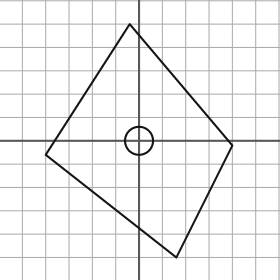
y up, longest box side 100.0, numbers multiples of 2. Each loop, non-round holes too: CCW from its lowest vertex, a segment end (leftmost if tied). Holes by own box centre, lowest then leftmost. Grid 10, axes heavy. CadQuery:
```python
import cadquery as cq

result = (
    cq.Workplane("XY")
    .moveTo(16.0, -50.0)
    .lineTo(40.0, -2.0)
    .lineTo(-4.0, 50.0)
    .lineTo(-40.0, -6.0)
    .close()
    .moveTo(0.0, 0.0)
    .circle(6.0)
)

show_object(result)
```